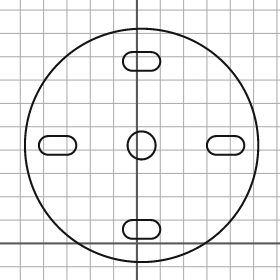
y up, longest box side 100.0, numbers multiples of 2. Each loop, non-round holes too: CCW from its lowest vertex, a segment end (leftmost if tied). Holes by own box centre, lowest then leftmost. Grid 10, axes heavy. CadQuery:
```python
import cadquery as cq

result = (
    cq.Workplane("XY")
    .moveTo(2.0, 42.0)
    .circle(50.0)
    .moveTo(-2.0, 2.0)
    .lineTo(6.0, 2.0)
    .threePointArc((10.0, 6.0), (6.0, 10.0))
    .lineTo(-2.0, 10.0)
    .threePointArc((-6.0, 6.0), (-2.0, 2.0))
    .close()
    .moveTo(-38.0, 38.0)
    .lineTo(-30.0, 38.0)
    .threePointArc((-26.0, 42.0), (-30.0, 46.0))
    .lineTo(-38.0, 46.0)
    .threePointArc((-42.0, 42.0), (-38.0, 38.0))
    .close()
    .moveTo(2.0, 42.0)
    .circle(6.0)
    .moveTo(34.0, 38.0)
    .lineTo(42.0, 38.0)
    .threePointArc((46.0, 42.0), (42.0, 46.0))
    .lineTo(34.0, 46.0)
    .threePointArc((30.0, 42.0), (34.0, 38.0))
    .close()
    .moveTo(-2.0, 74.0)
    .lineTo(6.0, 74.0)
    .threePointArc((10.0, 78.0), (6.0, 82.0))
    .lineTo(-2.0, 82.0)
    .threePointArc((-6.0, 78.0), (-2.0, 74.0))
    .close()
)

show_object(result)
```